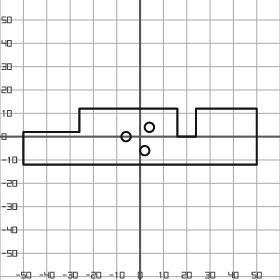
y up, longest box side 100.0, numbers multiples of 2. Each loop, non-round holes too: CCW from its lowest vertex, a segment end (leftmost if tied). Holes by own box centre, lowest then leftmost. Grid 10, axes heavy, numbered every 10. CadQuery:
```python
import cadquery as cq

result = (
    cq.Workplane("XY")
    .moveTo(-50.0, -12.0)
    .lineTo(50.0, -12.0)
    .lineTo(50.0, 12.0)
    .lineTo(24.0, 12.0)
    .lineTo(24.0, 0.0)
    .lineTo(16.0, 0.0)
    .lineTo(16.0, 12.0)
    .lineTo(-26.0, 12.0)
    .lineTo(-26.0, 2.0)
    .lineTo(-50.0, 2.0)
    .close()
    .moveTo(2.0, -6.0)
    .circle(2.0)
    .moveTo(-6.0, 0.0)
    .circle(2.0)
    .moveTo(4.0, 4.0)
    .circle(2.0)
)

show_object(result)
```